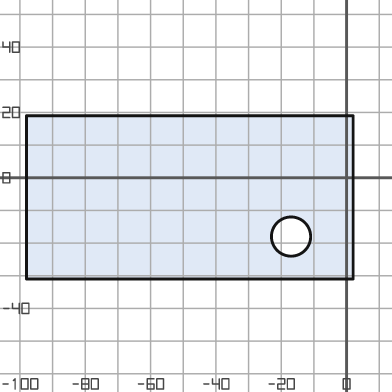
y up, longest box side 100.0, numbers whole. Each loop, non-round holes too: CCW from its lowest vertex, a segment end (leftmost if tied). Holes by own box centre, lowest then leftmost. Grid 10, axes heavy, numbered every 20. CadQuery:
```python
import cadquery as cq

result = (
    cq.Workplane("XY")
    .moveTo(-98.0, -31.0)
    .lineTo(2.0, -31.0)
    .lineTo(2.0, 19.0)
    .lineTo(-98.0, 19.0)
    .close()
    .moveTo(-17.0, -18.0)
    .circle(6.0)
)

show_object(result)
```